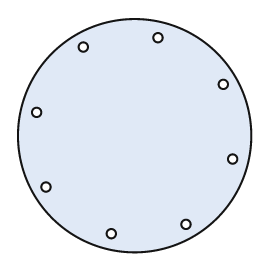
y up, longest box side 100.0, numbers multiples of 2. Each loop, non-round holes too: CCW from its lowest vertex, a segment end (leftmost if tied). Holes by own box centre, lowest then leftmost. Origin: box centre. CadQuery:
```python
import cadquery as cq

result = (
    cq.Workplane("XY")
    .moveTo(0.0, 0.0)
    .circle(50.0)
    .moveTo(-10.0, -42.0)
    .circle(2.0)
    .moveTo(22.0, -38.0)
    .circle(2.0)
    .moveTo(-38.0, -22.0)
    .circle(2.0)
    .moveTo(42.0, -10.0)
    .circle(2.0)
    .moveTo(-42.0, 10.0)
    .circle(2.0)
    .moveTo(38.0, 22.0)
    .circle(2.0)
    .moveTo(-22.0, 38.0)
    .circle(2.0)
    .moveTo(10.0, 42.0)
    .circle(2.0)
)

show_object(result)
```